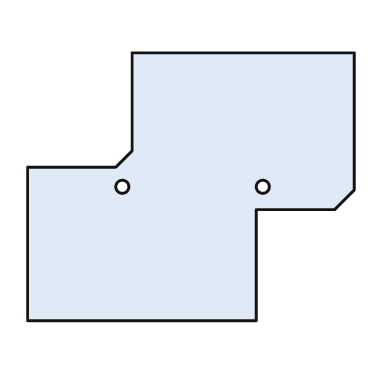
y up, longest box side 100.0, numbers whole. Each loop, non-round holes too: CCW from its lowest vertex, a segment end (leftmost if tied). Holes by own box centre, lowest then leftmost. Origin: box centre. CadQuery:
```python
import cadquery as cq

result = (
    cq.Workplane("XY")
    .moveTo(-50.0, -41.0)
    .lineTo(20.0, -41.0)
    .lineTo(20.0, -7.0)
    .lineTo(44.0, -7.0)
    .lineTo(50.0, -1.0)
    .lineTo(50.0, 41.0)
    .lineTo(-18.0, 41.0)
    .lineTo(-18.0, 11.0)
    .lineTo(-23.0, 6.0)
    .lineTo(-50.0, 6.0)
    .close()
    .moveTo(-21.0, 0.0)
    .circle(2.0)
    .moveTo(22.0, 0.0)
    .circle(2.0)
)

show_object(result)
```